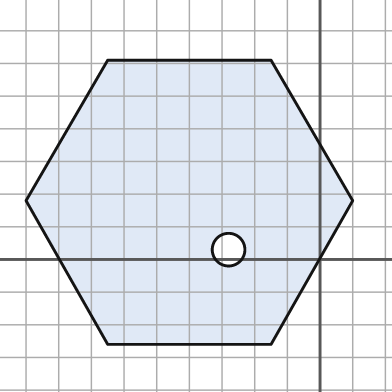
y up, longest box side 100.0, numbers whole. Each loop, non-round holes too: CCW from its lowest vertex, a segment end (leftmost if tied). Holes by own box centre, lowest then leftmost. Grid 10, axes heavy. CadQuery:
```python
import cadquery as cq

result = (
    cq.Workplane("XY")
    .moveTo(-65.0, -26.0)
    .lineTo(-15.0, -26.0)
    .lineTo(10.0, 18.0)
    .lineTo(-15.0, 61.0)
    .lineTo(-65.0, 61.0)
    .lineTo(-90.0, 18.0)
    .close()
    .moveTo(-28.0, 3.0)
    .circle(5.0)
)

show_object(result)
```